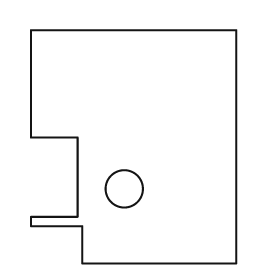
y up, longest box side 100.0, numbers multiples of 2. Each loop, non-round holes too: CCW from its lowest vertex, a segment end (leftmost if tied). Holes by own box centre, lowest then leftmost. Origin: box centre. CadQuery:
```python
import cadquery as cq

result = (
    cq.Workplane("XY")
    .moveTo(-22.0, -50.0)
    .lineTo(44.0, -50.0)
    .lineTo(44.0, 50.0)
    .lineTo(-44.0, 50.0)
    .lineTo(-44.0, 4.0)
    .lineTo(-24.0, 4.0)
    .lineTo(-24.0, -30.0)
    .lineTo(-44.0, -30.0)
    .lineTo(-44.0, -34.0)
    .lineTo(-22.0, -34.0)
    .close()
    .moveTo(-4.0, -18.0)
    .circle(8.0)
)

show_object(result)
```